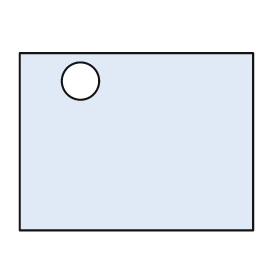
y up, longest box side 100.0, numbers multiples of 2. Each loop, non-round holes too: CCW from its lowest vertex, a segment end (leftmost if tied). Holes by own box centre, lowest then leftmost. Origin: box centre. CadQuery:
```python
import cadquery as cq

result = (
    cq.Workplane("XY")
    .moveTo(-50.0, -38.0)
    .lineTo(50.0, -38.0)
    .lineTo(50.0, 38.0)
    .lineTo(-50.0, 38.0)
    .close()
    .moveTo(-24.0, 26.0)
    .circle(8.0)
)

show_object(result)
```